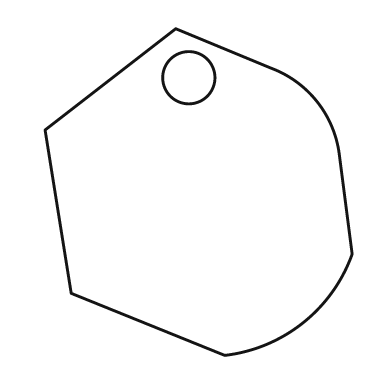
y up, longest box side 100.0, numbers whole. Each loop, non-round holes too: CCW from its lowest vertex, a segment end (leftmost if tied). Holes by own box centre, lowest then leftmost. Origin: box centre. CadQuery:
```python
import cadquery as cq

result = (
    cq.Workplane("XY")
    .moveTo(8.0, -50.0)
    .threePointArc((32.0, -40.0), (47.0, -19.0))
    .lineTo(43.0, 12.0)
    .threePointArc((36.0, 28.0), (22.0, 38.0))
    .lineTo(-7.0, 50.0)
    .lineTo(-47.0, 19.0)
    .lineTo(-39.0, -31.0)
    .close()
    .moveTo(-3.0, 35.0)
    .circle(8.0)
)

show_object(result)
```